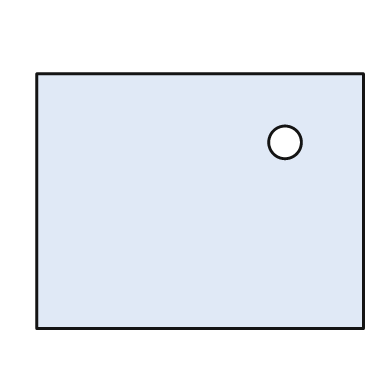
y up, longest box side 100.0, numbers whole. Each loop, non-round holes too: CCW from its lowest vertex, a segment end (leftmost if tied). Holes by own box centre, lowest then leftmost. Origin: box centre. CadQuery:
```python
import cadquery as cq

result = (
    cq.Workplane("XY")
    .moveTo(-50.0, -39.0)
    .lineTo(50.0, -39.0)
    .lineTo(50.0, 39.0)
    .lineTo(-50.0, 39.0)
    .close()
    .moveTo(26.0, 18.0)
    .circle(5.0)
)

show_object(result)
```